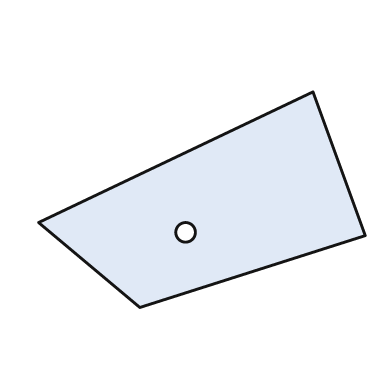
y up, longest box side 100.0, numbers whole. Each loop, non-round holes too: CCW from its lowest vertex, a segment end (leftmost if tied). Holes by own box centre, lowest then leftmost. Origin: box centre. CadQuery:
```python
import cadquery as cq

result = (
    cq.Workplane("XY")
    .moveTo(-19.0, -33.0)
    .lineTo(50.0, -11.0)
    .lineTo(34.0, 33.0)
    .lineTo(-50.0, -7.0)
    .close()
    .moveTo(-5.0, -10.0)
    .circle(3.0)
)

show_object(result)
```